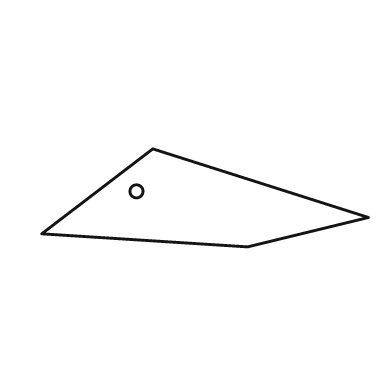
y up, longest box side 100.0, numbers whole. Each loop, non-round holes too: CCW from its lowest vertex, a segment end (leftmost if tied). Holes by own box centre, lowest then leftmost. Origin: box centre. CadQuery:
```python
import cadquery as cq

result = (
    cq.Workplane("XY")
    .moveTo(13.0, -15.0)
    .lineTo(50.0, -6.0)
    .lineTo(-16.0, 15.0)
    .lineTo(-50.0, -11.0)
    .close()
    .moveTo(-21.0, 2.0)
    .circle(2.0)
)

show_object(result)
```